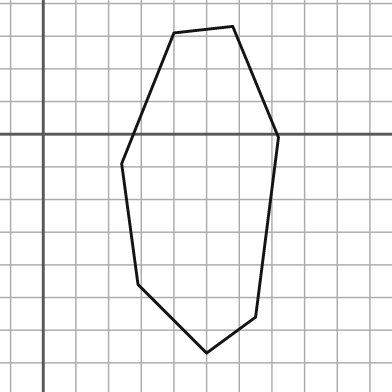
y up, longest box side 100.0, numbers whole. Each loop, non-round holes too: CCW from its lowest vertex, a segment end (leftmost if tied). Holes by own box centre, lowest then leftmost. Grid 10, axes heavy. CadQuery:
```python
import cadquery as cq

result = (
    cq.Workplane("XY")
    .moveTo(50.0, -67.0)
    .lineTo(65.0, -56.0)
    .lineTo(72.0, -1.0)
    .lineTo(58.0, 33.0)
    .lineTo(40.0, 31.0)
    .lineTo(24.0, -9.0)
    .lineTo(29.0, -46.0)
    .close()
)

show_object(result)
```